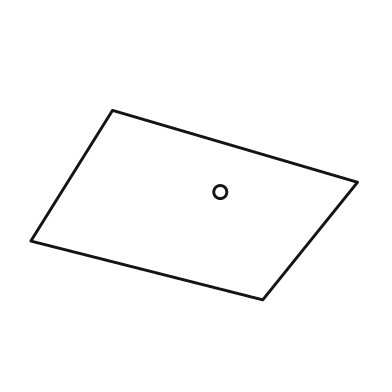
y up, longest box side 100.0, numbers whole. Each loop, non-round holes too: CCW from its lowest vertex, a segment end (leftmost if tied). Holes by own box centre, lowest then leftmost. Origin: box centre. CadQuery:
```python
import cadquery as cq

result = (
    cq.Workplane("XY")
    .moveTo(21.0, -29.0)
    .lineTo(50.0, 7.0)
    .lineTo(-25.0, 29.0)
    .lineTo(-50.0, -11.0)
    .close()
    .moveTo(8.0, 4.0)
    .circle(2.0)
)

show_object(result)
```